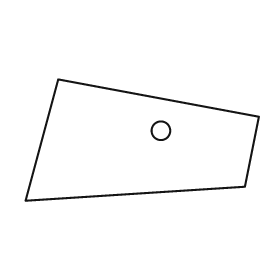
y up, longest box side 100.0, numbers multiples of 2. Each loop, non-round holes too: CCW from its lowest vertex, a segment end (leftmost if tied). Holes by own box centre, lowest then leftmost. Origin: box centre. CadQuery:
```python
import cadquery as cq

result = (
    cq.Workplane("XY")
    .moveTo(-50.0, -26.0)
    .lineTo(44.0, -20.0)
    .lineTo(50.0, 10.0)
    .lineTo(-36.0, 26.0)
    .close()
    .moveTo(8.0, 4.0)
    .circle(4.0)
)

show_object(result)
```